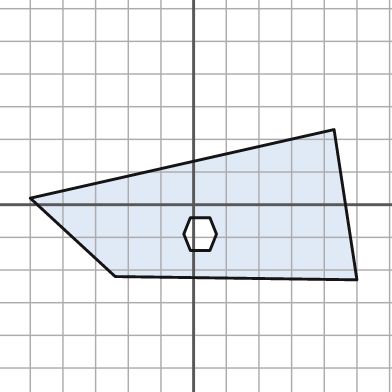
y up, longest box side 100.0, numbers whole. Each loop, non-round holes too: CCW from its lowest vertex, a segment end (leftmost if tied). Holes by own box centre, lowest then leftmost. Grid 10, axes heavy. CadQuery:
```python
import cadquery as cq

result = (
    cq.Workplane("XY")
    .moveTo(50.0, -23.0)
    .lineTo(43.0, 23.0)
    .lineTo(-50.0, 2.0)
    .lineTo(-24.0, -22.0)
    .close()
    .moveTo(-1.0, -14.0)
    .lineTo(5.0, -14.0)
    .lineTo(7.0, -9.0)
    .lineTo(5.0, -4.0)
    .lineTo(-1.0, -4.0)
    .lineTo(-3.0, -9.0)
    .close()
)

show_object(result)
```